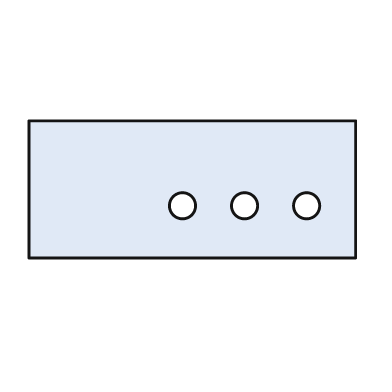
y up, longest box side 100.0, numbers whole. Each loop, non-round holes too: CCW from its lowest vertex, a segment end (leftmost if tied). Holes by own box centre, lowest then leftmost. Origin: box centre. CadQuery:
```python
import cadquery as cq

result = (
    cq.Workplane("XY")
    .moveTo(-50.0, -21.0)
    .lineTo(50.0, -21.0)
    .lineTo(50.0, 21.0)
    .lineTo(-50.0, 21.0)
    .close()
    .moveTo(-3.0, -5.0)
    .circle(4.0)
    .moveTo(16.0, -5.0)
    .circle(4.0)
    .moveTo(35.0, -5.0)
    .circle(4.0)
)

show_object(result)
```